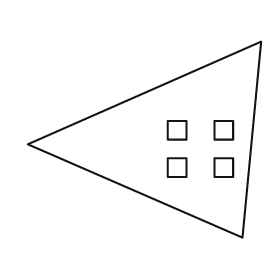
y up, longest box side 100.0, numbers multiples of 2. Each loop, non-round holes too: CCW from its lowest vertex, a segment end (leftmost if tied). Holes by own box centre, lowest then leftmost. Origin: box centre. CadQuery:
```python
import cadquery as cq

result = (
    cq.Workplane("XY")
    .moveTo(42.0, -42.0)
    .lineTo(50.0, 42.0)
    .lineTo(-50.0, -2.0)
    .close()
    .moveTo(10.0, -16.0)
    .lineTo(18.0, -16.0)
    .lineTo(18.0, -8.0)
    .lineTo(10.0, -8.0)
    .close()
    .moveTo(30.0, -16.0)
    .lineTo(38.0, -16.0)
    .lineTo(38.0, -8.0)
    .lineTo(30.0, -8.0)
    .close()
    .moveTo(10.0, 0.0)
    .lineTo(18.0, 0.0)
    .lineTo(18.0, 8.0)
    .lineTo(10.0, 8.0)
    .close()
    .moveTo(30.0, 0.0)
    .lineTo(38.0, 0.0)
    .lineTo(38.0, 8.0)
    .lineTo(30.0, 8.0)
    .close()
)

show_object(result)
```